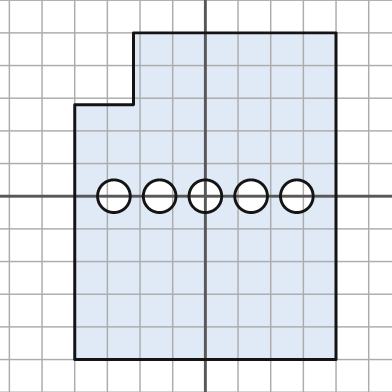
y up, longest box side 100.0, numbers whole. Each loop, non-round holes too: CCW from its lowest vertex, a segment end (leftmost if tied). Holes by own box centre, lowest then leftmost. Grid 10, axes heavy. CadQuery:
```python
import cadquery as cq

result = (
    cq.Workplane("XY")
    .moveTo(-40.0, -50.0)
    .lineTo(40.0, -50.0)
    .lineTo(40.0, 50.0)
    .lineTo(-22.0, 50.0)
    .lineTo(-22.0, 28.0)
    .lineTo(-40.0, 28.0)
    .close()
    .moveTo(-28.0, 0.0)
    .circle(5.0)
    .moveTo(-14.0, 0.0)
    .circle(5.0)
    .moveTo(0.0, 0.0)
    .circle(5.0)
    .moveTo(14.0, 0.0)
    .circle(5.0)
    .moveTo(28.0, 0.0)
    .circle(5.0)
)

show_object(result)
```